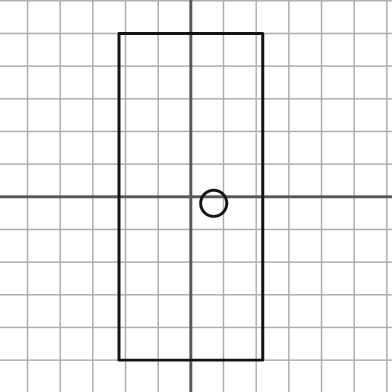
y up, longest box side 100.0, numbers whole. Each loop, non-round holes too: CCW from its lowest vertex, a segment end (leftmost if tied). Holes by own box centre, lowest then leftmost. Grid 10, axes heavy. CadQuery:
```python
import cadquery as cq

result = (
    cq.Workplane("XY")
    .moveTo(-22.0, -50.0)
    .lineTo(22.0, -50.0)
    .lineTo(22.0, 50.0)
    .lineTo(-22.0, 50.0)
    .close()
    .moveTo(7.0, -2.0)
    .circle(4.0)
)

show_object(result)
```